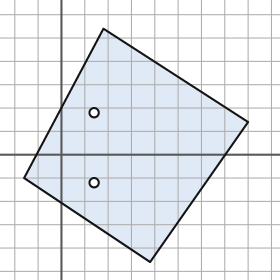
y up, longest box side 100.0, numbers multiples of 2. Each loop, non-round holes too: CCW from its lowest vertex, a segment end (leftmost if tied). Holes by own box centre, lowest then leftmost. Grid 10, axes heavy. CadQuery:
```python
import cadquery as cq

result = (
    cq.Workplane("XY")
    .moveTo(38.0, -46.0)
    .lineTo(80.0, 14.0)
    .lineTo(18.0, 54.0)
    .lineTo(-16.0, -10.0)
    .close()
    .moveTo(14.0, -12.0)
    .circle(2.0)
    .moveTo(14.0, 18.0)
    .circle(2.0)
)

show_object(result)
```